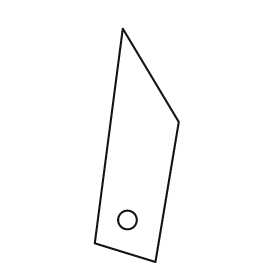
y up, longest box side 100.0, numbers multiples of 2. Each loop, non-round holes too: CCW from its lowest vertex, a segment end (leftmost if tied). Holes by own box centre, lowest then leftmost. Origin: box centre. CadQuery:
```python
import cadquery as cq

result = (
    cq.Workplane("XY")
    .moveTo(8.0, -50.0)
    .lineTo(18.0, 10.0)
    .lineTo(-6.0, 50.0)
    .lineTo(-18.0, -42.0)
    .close()
    .moveTo(-4.0, -32.0)
    .circle(4.0)
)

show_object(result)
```